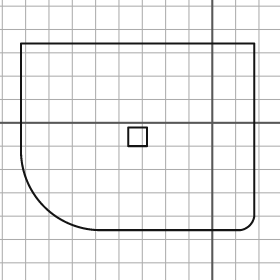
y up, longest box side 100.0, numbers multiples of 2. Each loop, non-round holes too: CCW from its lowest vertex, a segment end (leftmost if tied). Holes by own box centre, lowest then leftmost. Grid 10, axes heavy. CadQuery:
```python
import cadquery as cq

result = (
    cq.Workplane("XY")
    .moveTo(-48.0, -46.0)
    .lineTo(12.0, -46.0)
    .threePointArc((16.0, -44.0), (18.0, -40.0))
    .lineTo(18.0, 34.0)
    .lineTo(-82.0, 34.0)
    .lineTo(-82.0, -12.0)
    .threePointArc((-72.0, -36.0), (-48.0, -46.0))
    .close()
    .moveTo(-36.0, -10.0)
    .lineTo(-28.0, -10.0)
    .lineTo(-28.0, -2.0)
    .lineTo(-36.0, -2.0)
    .close()
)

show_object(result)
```